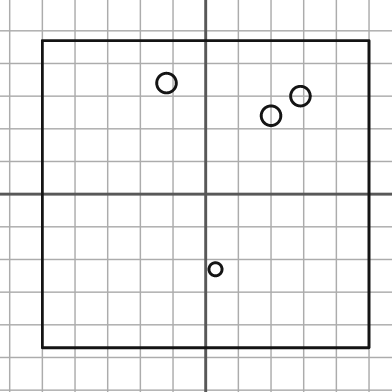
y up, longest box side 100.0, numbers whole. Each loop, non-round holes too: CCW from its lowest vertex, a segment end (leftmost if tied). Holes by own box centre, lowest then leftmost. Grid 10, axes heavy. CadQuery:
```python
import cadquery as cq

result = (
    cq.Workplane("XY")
    .moveTo(-50.0, -47.0)
    .lineTo(50.0, -47.0)
    .lineTo(50.0, 47.0)
    .lineTo(-50.0, 47.0)
    .close()
    .moveTo(3.0, -23.0)
    .circle(2.0)
    .moveTo(20.0, 24.0)
    .circle(3.0)
    .moveTo(29.0, 30.0)
    .circle(3.0)
    .moveTo(-12.0, 34.0)
    .circle(3.0)
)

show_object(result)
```